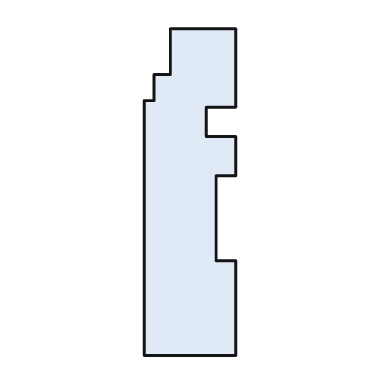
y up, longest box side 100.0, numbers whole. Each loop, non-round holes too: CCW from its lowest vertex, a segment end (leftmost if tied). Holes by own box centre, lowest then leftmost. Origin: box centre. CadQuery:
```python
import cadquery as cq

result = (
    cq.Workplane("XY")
    .moveTo(-14.0, -50.0)
    .lineTo(14.0, -50.0)
    .lineTo(14.0, -21.0)
    .lineTo(8.0, -21.0)
    .lineTo(8.0, 5.0)
    .lineTo(14.0, 5.0)
    .lineTo(14.0, 17.0)
    .lineTo(5.0, 17.0)
    .lineTo(5.0, 26.0)
    .lineTo(14.0, 26.0)
    .lineTo(14.0, 50.0)
    .lineTo(-6.0, 50.0)
    .lineTo(-6.0, 36.0)
    .lineTo(-11.0, 36.0)
    .lineTo(-11.0, 28.0)
    .lineTo(-14.0, 28.0)
    .close()
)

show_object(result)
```